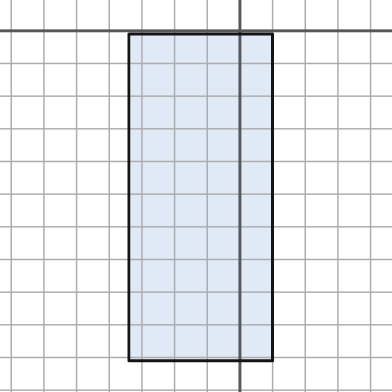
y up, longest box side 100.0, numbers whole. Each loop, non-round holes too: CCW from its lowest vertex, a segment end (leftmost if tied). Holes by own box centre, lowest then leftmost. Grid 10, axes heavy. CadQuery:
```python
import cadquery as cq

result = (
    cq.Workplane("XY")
    .moveTo(-34.0, -101.0)
    .lineTo(10.0, -101.0)
    .lineTo(10.0, -1.0)
    .lineTo(-34.0, -1.0)
    .close()
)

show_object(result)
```